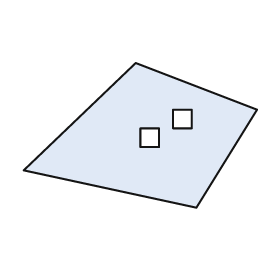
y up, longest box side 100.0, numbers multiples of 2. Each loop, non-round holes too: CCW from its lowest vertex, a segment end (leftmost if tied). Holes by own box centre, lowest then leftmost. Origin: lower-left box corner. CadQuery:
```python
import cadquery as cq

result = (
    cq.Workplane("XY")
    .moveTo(74.0, 0.0)
    .lineTo(100.0, 42.0)
    .lineTo(48.0, 62.0)
    .lineTo(0.0, 16.0)
    .close()
    .moveTo(50.0, 26.0)
    .lineTo(58.0, 26.0)
    .lineTo(58.0, 34.0)
    .lineTo(50.0, 34.0)
    .close()
    .moveTo(64.0, 34.0)
    .lineTo(72.0, 34.0)
    .lineTo(72.0, 42.0)
    .lineTo(64.0, 42.0)
    .close()
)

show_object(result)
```